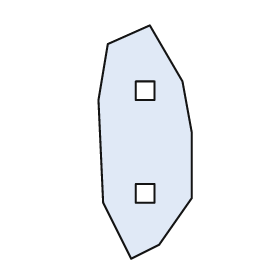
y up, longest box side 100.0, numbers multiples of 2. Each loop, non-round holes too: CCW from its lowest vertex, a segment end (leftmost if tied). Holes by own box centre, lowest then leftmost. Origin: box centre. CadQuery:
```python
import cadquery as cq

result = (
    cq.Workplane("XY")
    .moveTo(-6.0, -50.0)
    .lineTo(6.0, -44.0)
    .lineTo(20.0, -24.0)
    .lineTo(20.0, 4.0)
    .lineTo(16.0, 26.0)
    .lineTo(2.0, 50.0)
    .lineTo(-16.0, 42.0)
    .lineTo(-20.0, 18.0)
    .lineTo(-18.0, -26.0)
    .close()
    .moveTo(-4.0, -26.0)
    .lineTo(4.0, -26.0)
    .lineTo(4.0, -18.0)
    .lineTo(-4.0, -18.0)
    .close()
    .moveTo(-4.0, 18.0)
    .lineTo(4.0, 18.0)
    .lineTo(4.0, 26.0)
    .lineTo(-4.0, 26.0)
    .close()
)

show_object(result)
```